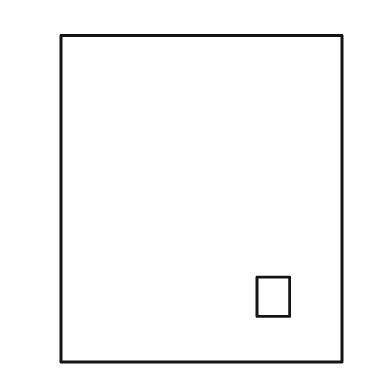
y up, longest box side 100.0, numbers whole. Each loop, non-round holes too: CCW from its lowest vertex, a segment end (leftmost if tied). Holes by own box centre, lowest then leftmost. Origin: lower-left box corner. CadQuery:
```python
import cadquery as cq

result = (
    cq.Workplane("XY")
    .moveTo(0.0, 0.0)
    .lineTo(86.0, 0.0)
    .lineTo(86.0, 100.0)
    .lineTo(0.0, 100.0)
    .close()
    .moveTo(60.0, 14.0)
    .lineTo(70.0, 14.0)
    .lineTo(70.0, 26.0)
    .lineTo(60.0, 26.0)
    .close()
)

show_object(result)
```